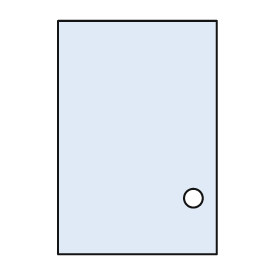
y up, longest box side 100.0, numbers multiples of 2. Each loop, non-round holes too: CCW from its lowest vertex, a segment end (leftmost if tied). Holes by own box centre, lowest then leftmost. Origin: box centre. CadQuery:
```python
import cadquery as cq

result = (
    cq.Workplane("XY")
    .moveTo(-34.0, -50.0)
    .lineTo(34.0, -50.0)
    .lineTo(34.0, 50.0)
    .lineTo(-34.0, 50.0)
    .close()
    .moveTo(24.0, -26.0)
    .circle(4.0)
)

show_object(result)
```